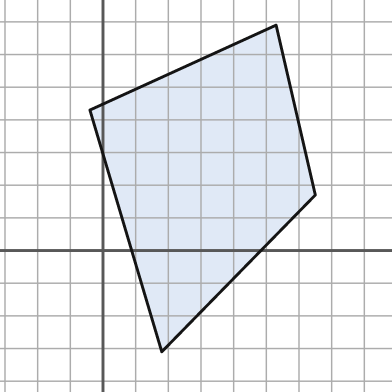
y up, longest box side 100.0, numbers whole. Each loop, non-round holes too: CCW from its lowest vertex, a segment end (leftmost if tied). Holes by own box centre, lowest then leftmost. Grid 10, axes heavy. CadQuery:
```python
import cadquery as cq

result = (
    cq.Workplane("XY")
    .moveTo(18.0, -31.0)
    .lineTo(65.0, 17.0)
    .lineTo(53.0, 69.0)
    .lineTo(-4.0, 43.0)
    .close()
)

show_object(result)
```